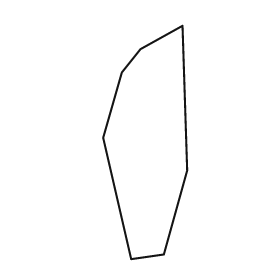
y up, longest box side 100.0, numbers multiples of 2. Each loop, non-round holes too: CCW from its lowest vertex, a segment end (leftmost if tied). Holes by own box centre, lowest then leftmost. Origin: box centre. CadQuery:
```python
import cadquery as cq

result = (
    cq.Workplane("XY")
    .moveTo(-6.0, -50.0)
    .lineTo(8.0, -48.0)
    .lineTo(18.0, -12.0)
    .lineTo(16.0, 50.0)
    .lineTo(-2.0, 40.0)
    .lineTo(-10.0, 30.0)
    .lineTo(-18.0, 2.0)
    .close()
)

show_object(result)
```